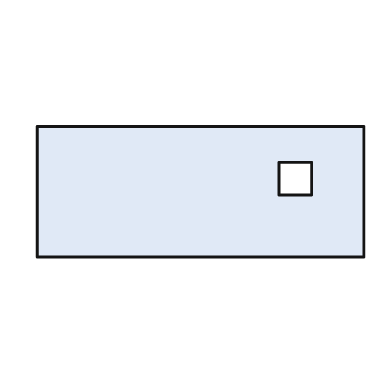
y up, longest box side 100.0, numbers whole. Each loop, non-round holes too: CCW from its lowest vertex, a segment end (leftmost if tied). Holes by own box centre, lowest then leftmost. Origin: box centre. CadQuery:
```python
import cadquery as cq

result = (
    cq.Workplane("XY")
    .moveTo(-50.0, -20.0)
    .lineTo(50.0, -20.0)
    .lineTo(50.0, 20.0)
    .lineTo(-50.0, 20.0)
    .close()
    .moveTo(24.0, -1.0)
    .lineTo(34.0, -1.0)
    .lineTo(34.0, 9.0)
    .lineTo(24.0, 9.0)
    .close()
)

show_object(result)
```